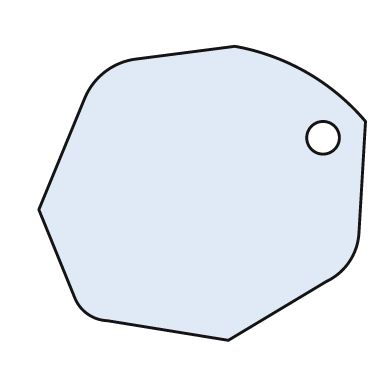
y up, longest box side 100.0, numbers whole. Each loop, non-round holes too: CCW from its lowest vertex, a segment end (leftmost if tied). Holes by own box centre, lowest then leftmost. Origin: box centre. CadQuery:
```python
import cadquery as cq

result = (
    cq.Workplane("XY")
    .moveTo(8.0, -45.0)
    .lineTo(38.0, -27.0)
    .threePointArc((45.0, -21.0), (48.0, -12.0))
    .lineTo(50.0, 22.0)
    .threePointArc((32.0, 37.0), (10.0, 45.0))
    .lineTo(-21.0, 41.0)
    .threePointArc((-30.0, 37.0), (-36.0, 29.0))
    .lineTo(-50.0, -5.0)
    .lineTo(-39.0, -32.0)
    .threePointArc((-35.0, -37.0), (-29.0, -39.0))
    .close()
    .moveTo(37.0, 17.0)
    .circle(5.0)
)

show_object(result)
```